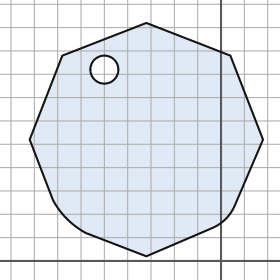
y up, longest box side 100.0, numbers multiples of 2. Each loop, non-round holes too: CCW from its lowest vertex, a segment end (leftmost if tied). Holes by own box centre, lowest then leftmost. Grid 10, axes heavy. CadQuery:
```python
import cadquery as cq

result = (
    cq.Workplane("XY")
    .moveTo(-32.0, 2.0)
    .lineTo(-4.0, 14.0)
    .threePointArc((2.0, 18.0), (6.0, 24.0))
    .lineTo(18.0, 52.0)
    .lineTo(4.0, 88.0)
    .lineTo(-32.0, 102.0)
    .lineTo(-68.0, 88.0)
    .lineTo(-82.0, 52.0)
    .lineTo(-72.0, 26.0)
    .threePointArc((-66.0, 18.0), (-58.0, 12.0))
    .close()
    .moveTo(-50.0, 82.0)
    .circle(6.0)
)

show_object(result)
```